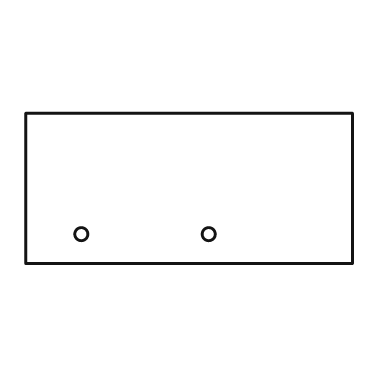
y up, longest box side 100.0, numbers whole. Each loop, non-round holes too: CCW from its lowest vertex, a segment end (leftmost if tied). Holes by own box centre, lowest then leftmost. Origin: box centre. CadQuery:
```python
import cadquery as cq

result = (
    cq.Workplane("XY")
    .moveTo(-50.0, -23.0)
    .lineTo(50.0, -23.0)
    .lineTo(50.0, 23.0)
    .lineTo(-50.0, 23.0)
    .close()
    .moveTo(-33.0, -14.0)
    .circle(2.0)
    .moveTo(6.0, -14.0)
    .circle(2.0)
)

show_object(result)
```